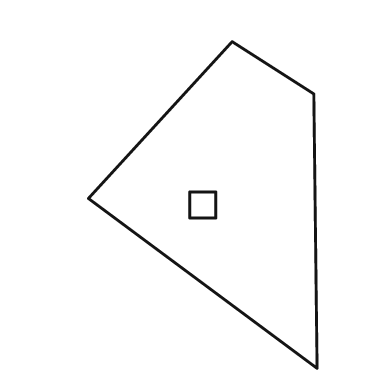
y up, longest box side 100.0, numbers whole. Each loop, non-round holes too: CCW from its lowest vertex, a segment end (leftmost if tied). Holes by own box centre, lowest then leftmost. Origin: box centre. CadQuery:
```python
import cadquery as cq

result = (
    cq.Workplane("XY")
    .moveTo(35.0, -50.0)
    .lineTo(34.0, 34.0)
    .lineTo(9.0, 50.0)
    .lineTo(-35.0, 2.0)
    .close()
    .moveTo(-4.0, -4.0)
    .lineTo(4.0, -4.0)
    .lineTo(4.0, 4.0)
    .lineTo(-4.0, 4.0)
    .close()
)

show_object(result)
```